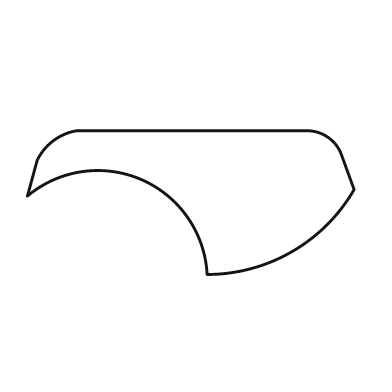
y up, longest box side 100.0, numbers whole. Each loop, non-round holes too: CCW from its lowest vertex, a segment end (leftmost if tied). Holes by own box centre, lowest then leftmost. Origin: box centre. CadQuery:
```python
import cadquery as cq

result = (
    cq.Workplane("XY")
    .moveTo(5.0, -22.0)
    .threePointArc((31.0, -15.0), (50.0, 4.0))
    .lineTo(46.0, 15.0)
    .threePointArc((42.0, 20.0), (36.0, 22.0))
    .lineTo(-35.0, 22.0)
    .threePointArc((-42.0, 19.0), (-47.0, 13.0))
    .lineTo(-50.0, 2.0)
    .threePointArc((-15.0, 7.0), (5.0, -22.0))
    .close()
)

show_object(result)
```